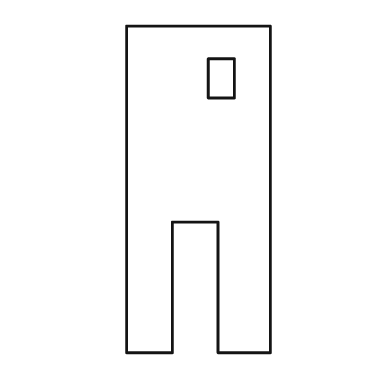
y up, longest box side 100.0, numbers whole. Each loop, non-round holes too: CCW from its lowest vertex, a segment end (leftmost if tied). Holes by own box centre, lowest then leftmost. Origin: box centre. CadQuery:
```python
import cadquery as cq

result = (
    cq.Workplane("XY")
    .moveTo(-22.0, -50.0)
    .lineTo(-8.0, -50.0)
    .lineTo(-8.0, -10.0)
    .lineTo(6.0, -10.0)
    .lineTo(6.0, -50.0)
    .lineTo(22.0, -50.0)
    .lineTo(22.0, 50.0)
    .lineTo(-22.0, 50.0)
    .close()
    .moveTo(3.0, 28.0)
    .lineTo(11.0, 28.0)
    .lineTo(11.0, 40.0)
    .lineTo(3.0, 40.0)
    .close()
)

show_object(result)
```